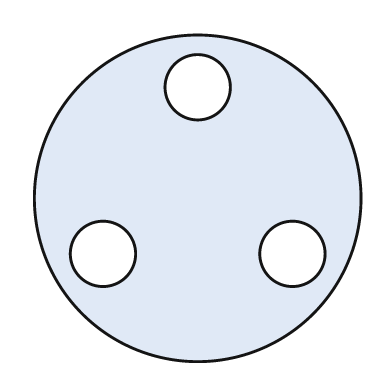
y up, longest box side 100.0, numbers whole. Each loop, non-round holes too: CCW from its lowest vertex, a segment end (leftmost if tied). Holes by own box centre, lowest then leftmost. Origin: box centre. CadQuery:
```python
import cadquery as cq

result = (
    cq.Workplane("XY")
    .moveTo(0.0, 0.0)
    .circle(50.0)
    .moveTo(-29.0, -17.0)
    .circle(10.0)
    .moveTo(29.0, -17.0)
    .circle(10.0)
    .moveTo(0.0, 34.0)
    .circle(10.0)
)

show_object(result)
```